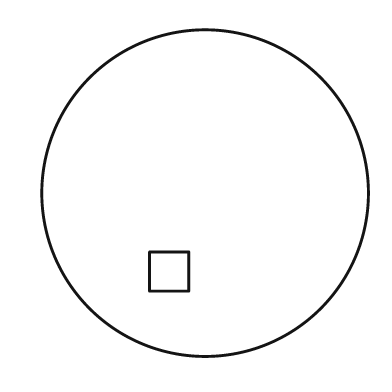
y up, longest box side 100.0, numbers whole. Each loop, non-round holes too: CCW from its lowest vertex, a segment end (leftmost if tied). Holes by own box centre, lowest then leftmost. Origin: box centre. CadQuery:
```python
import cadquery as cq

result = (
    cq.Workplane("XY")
    .moveTo(0.0, 0.0)
    .circle(50.0)
    .moveTo(-17.0, -30.0)
    .lineTo(-5.0, -30.0)
    .lineTo(-5.0, -18.0)
    .lineTo(-17.0, -18.0)
    .close()
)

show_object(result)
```